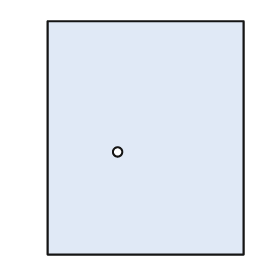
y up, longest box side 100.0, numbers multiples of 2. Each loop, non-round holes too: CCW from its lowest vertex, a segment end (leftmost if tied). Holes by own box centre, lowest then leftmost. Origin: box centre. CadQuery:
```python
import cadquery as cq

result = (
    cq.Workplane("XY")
    .moveTo(-42.0, -50.0)
    .lineTo(42.0, -50.0)
    .lineTo(42.0, 50.0)
    .lineTo(-42.0, 50.0)
    .close()
    .moveTo(-12.0, -6.0)
    .circle(2.0)
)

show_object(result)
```